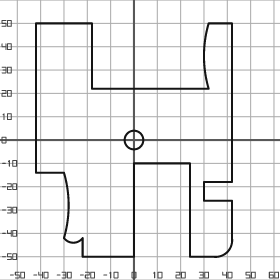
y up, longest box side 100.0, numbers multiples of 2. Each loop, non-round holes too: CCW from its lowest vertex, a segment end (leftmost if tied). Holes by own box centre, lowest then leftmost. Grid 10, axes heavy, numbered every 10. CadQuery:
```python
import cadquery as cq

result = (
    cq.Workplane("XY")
    .moveTo(-22.0, -50.0)
    .lineTo(0.0, -50.0)
    .lineTo(0.0, -10.0)
    .lineTo(24.0, -10.0)
    .lineTo(24.0, -50.0)
    .lineTo(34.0, -50.0)
    .threePointArc((40.0, -48.0), (42.0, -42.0))
    .lineTo(42.0, -26.0)
    .lineTo(30.0, -26.0)
    .lineTo(30.0, -18.0)
    .lineTo(42.0, -18.0)
    .lineTo(42.0, 50.0)
    .lineTo(32.0, 50.0)
    .threePointArc((30.0, 36.0), (32.0, 22.0))
    .lineTo(-18.0, 22.0)
    .lineTo(-18.0, 50.0)
    .lineTo(-42.0, 50.0)
    .lineTo(-42.0, -14.0)
    .lineTo(-30.0, -14.0)
    .threePointArc((-28.0, -28.0), (-30.0, -42.0))
    .threePointArc((-26.0, -44.0), (-22.0, -42.0))
    .close()
    .moveTo(0.0, 0.0)
    .circle(4.0)
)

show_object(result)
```